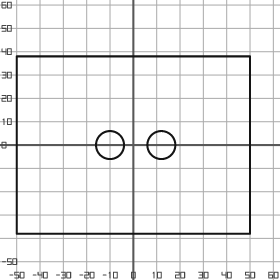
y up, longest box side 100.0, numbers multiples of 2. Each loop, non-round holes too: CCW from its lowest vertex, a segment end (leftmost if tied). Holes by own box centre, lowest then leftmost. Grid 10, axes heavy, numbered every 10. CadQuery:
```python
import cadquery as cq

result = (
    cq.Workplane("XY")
    .moveTo(-50.0, -38.0)
    .lineTo(50.0, -38.0)
    .lineTo(50.0, 38.0)
    .lineTo(-50.0, 38.0)
    .close()
    .moveTo(-10.0, 0.0)
    .circle(6.0)
    .moveTo(12.0, 0.0)
    .circle(6.0)
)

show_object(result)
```